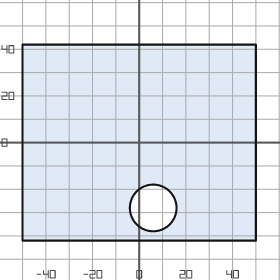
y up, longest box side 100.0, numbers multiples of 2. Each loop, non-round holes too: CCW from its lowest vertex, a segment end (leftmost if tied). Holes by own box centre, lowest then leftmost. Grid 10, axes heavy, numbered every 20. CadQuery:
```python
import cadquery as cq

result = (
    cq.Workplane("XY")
    .moveTo(-50.0, -42.0)
    .lineTo(50.0, -42.0)
    .lineTo(50.0, 42.0)
    .lineTo(-50.0, 42.0)
    .close()
    .moveTo(6.0, -28.0)
    .circle(10.0)
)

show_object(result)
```